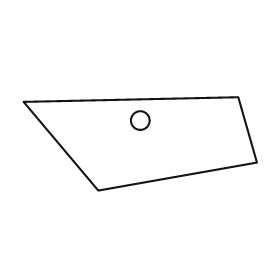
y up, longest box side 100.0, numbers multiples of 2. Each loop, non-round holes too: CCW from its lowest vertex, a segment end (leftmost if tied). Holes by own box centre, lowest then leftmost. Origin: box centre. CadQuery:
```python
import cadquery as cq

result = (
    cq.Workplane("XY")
    .moveTo(-18.0, -20.0)
    .lineTo(50.0, -8.0)
    .lineTo(42.0, 20.0)
    .lineTo(-50.0, 18.0)
    .close()
    .moveTo(0.0, 10.0)
    .circle(4.0)
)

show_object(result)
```